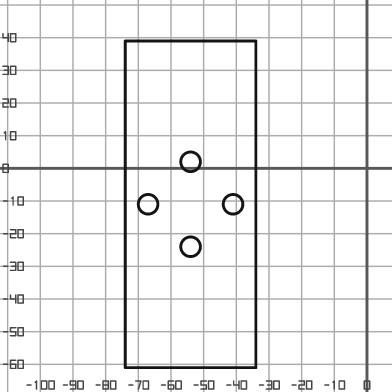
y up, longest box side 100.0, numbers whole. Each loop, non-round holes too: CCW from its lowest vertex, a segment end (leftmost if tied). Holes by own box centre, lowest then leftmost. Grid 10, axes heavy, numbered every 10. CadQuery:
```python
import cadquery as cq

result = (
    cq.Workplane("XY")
    .moveTo(-74.0, -61.0)
    .lineTo(-34.0, -61.0)
    .lineTo(-34.0, 39.0)
    .lineTo(-74.0, 39.0)
    .close()
    .moveTo(-54.0, -24.0)
    .circle(3.0)
    .moveTo(-67.0, -11.0)
    .circle(3.0)
    .moveTo(-41.0, -11.0)
    .circle(3.0)
    .moveTo(-54.0, 2.0)
    .circle(3.0)
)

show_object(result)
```